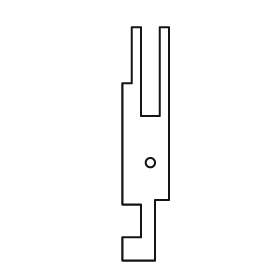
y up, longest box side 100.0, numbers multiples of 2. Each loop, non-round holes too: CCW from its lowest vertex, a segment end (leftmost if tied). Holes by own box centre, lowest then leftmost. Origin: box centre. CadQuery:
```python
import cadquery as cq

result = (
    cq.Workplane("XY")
    .moveTo(-10.0, -50.0)
    .lineTo(4.0, -50.0)
    .lineTo(4.0, -24.0)
    .lineTo(10.0, -24.0)
    .lineTo(10.0, 50.0)
    .lineTo(6.0, 50.0)
    .lineTo(6.0, 12.0)
    .lineTo(-2.0, 12.0)
    .lineTo(-2.0, 50.0)
    .lineTo(-6.0, 50.0)
    .lineTo(-6.0, 26.0)
    .lineTo(-10.0, 26.0)
    .lineTo(-10.0, -26.0)
    .lineTo(-2.0, -26.0)
    .lineTo(-2.0, -40.0)
    .lineTo(-10.0, -40.0)
    .close()
    .moveTo(2.0, -8.0)
    .circle(2.0)
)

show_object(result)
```